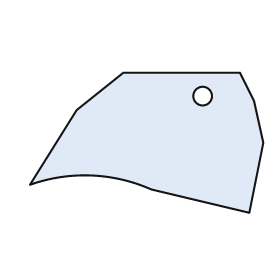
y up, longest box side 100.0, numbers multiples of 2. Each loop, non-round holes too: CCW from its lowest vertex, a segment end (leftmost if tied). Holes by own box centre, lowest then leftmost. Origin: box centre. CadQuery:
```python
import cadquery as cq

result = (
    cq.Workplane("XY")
    .moveTo(44.0, -30.0)
    .lineTo(50.0, 0.0)
    .lineTo(46.0, 18.0)
    .lineTo(40.0, 30.0)
    .lineTo(-10.0, 30.0)
    .lineTo(-30.0, 14.0)
    .lineTo(-50.0, -18.0)
    .threePointArc((-24.0, -14.0), (2.0, -20.0))
    .close()
    .moveTo(24.0, 20.0)
    .circle(4.0)
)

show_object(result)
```